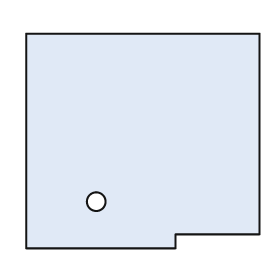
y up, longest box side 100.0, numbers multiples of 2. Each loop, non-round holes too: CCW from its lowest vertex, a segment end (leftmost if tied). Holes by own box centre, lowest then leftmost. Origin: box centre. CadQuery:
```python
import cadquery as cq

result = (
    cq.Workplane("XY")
    .moveTo(-50.0, -46.0)
    .lineTo(14.0, -46.0)
    .lineTo(14.0, -40.0)
    .lineTo(50.0, -40.0)
    .lineTo(50.0, 46.0)
    .lineTo(-50.0, 46.0)
    .close()
    .moveTo(-20.0, -26.0)
    .circle(4.0)
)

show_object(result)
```